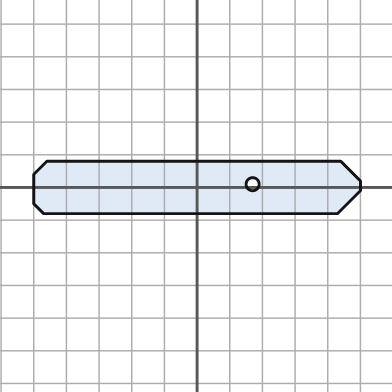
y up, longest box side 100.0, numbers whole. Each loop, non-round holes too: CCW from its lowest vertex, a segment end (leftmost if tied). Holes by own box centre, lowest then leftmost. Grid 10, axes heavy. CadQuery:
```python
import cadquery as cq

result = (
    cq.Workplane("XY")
    .moveTo(-47.0, -8.0)
    .lineTo(43.0, -8.0)
    .lineTo(50.0, -1.0)
    .lineTo(50.0, 2.0)
    .lineTo(44.0, 8.0)
    .lineTo(-46.0, 8.0)
    .lineTo(-50.0, 4.0)
    .lineTo(-50.0, -5.0)
    .close()
    .moveTo(17.0, 1.0)
    .circle(2.0)
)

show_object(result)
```